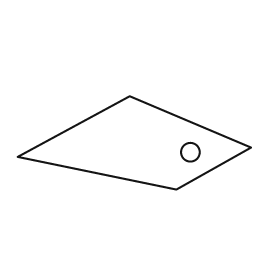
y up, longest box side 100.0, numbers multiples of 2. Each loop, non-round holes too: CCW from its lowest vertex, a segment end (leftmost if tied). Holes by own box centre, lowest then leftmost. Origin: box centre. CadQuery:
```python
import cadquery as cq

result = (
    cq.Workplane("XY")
    .moveTo(18.0, -20.0)
    .lineTo(50.0, -2.0)
    .lineTo(-2.0, 20.0)
    .lineTo(-50.0, -6.0)
    .close()
    .moveTo(24.0, -4.0)
    .circle(4.0)
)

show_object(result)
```